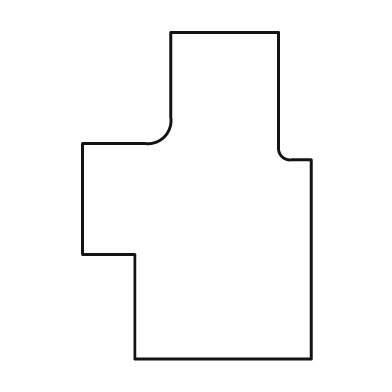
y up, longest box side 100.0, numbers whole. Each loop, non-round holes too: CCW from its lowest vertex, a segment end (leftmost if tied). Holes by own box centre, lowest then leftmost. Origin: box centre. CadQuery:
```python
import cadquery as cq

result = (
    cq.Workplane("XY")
    .moveTo(-19.0, -50.0)
    .lineTo(35.0, -50.0)
    .lineTo(35.0, 11.0)
    .lineTo(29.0, 11.0)
    .threePointArc((26.0, 12.0), (25.0, 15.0))
    .lineTo(25.0, 50.0)
    .lineTo(-8.0, 50.0)
    .lineTo(-8.0, 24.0)
    .threePointArc((-10.0, 18.0), (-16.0, 16.0))
    .lineTo(-35.0, 16.0)
    .lineTo(-35.0, -18.0)
    .lineTo(-19.0, -18.0)
    .close()
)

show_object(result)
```